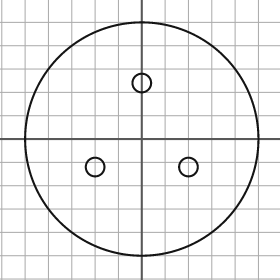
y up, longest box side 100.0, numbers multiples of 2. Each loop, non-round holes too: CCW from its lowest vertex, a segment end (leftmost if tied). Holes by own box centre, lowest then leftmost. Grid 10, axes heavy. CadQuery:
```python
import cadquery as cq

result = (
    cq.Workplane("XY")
    .moveTo(0.0, 0.0)
    .circle(50.0)
    .moveTo(-20.0, -12.0)
    .circle(4.0)
    .moveTo(20.0, -12.0)
    .circle(4.0)
    .moveTo(0.0, 24.0)
    .circle(4.0)
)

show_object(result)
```